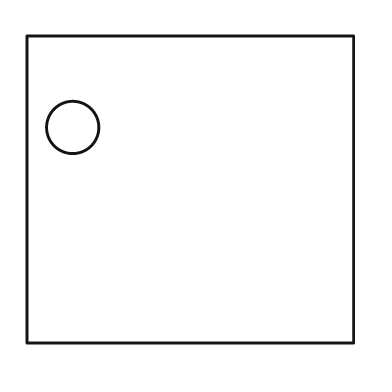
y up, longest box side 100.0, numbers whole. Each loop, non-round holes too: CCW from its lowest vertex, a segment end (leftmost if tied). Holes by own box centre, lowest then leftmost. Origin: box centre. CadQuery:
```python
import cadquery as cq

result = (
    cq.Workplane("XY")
    .moveTo(-50.0, -47.0)
    .lineTo(50.0, -47.0)
    .lineTo(50.0, 47.0)
    .lineTo(-50.0, 47.0)
    .close()
    .moveTo(-36.0, 19.0)
    .circle(8.0)
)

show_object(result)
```